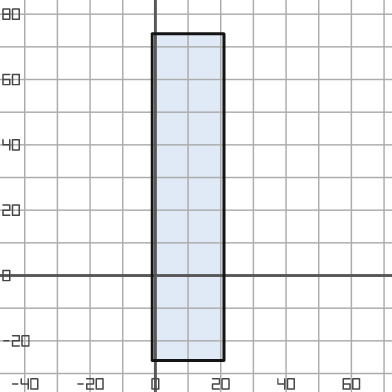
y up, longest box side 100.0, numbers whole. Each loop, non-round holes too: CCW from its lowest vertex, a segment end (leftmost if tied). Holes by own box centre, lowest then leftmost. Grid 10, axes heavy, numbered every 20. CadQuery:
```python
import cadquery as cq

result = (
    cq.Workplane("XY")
    .moveTo(-1.0, -26.0)
    .lineTo(21.0, -26.0)
    .lineTo(21.0, 74.0)
    .lineTo(-1.0, 74.0)
    .close()
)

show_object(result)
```